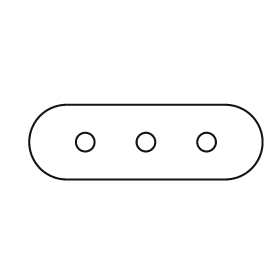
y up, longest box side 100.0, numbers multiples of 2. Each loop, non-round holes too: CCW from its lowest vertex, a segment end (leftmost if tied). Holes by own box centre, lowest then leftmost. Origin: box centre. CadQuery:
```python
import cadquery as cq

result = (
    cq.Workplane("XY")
    .moveTo(-34.0, -16.0)
    .lineTo(34.0, -16.0)
    .threePointArc((50.0, 0.0), (34.0, 16.0))
    .lineTo(-34.0, 16.0)
    .threePointArc((-50.0, 0.0), (-34.0, -16.0))
    .close()
    .moveTo(-26.0, 0.0)
    .circle(4.0)
    .moveTo(0.0, 0.0)
    .circle(4.0)
    .moveTo(26.0, 0.0)
    .circle(4.0)
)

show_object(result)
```